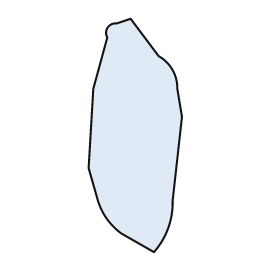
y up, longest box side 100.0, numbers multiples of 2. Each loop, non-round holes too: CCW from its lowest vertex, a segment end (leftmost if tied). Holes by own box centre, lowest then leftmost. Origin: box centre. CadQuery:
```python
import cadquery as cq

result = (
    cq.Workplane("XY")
    .moveTo(8.0, -50.0)
    .threePointArc((14.0, -40.0), (16.0, -28.0))
    .lineTo(20.0, 8.0)
    .lineTo(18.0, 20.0)
    .threePointArc((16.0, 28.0), (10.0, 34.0))
    .lineTo(-2.0, 50.0)
    .lineTo(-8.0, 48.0)
    .threePointArc((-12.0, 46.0), (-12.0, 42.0))
    .lineTo(-18.0, 20.0)
    .lineTo(-20.0, -14.0)
    .lineTo(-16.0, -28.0)
    .threePointArc((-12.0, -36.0), (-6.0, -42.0))
    .close()
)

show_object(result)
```